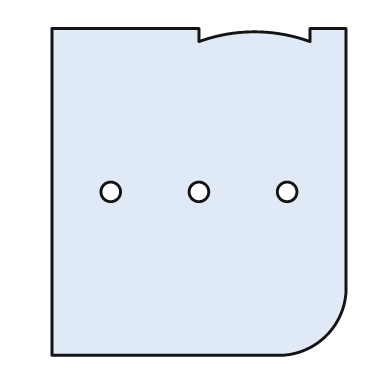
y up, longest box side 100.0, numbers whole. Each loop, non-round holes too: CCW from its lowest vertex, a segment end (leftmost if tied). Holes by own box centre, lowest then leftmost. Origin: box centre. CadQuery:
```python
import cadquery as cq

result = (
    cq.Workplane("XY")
    .moveTo(-45.0, -50.0)
    .lineTo(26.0, -50.0)
    .threePointArc((39.0, -44.0), (45.0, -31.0))
    .lineTo(45.0, 50.0)
    .lineTo(34.0, 50.0)
    .lineTo(34.0, 46.0)
    .threePointArc((17.0, 49.0), (0.0, 46.0))
    .lineTo(0.0, 50.0)
    .lineTo(-45.0, 50.0)
    .close()
    .moveTo(-27.0, 0.0)
    .circle(3.0)
    .moveTo(0.0, 0.0)
    .circle(3.0)
    .moveTo(27.0, 0.0)
    .circle(3.0)
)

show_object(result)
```